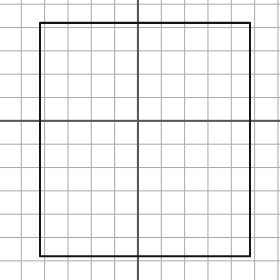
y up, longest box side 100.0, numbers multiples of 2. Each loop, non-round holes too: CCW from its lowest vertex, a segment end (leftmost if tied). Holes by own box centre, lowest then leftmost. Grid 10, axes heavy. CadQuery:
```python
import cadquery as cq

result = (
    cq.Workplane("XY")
    .moveTo(-42.0, -58.0)
    .lineTo(48.0, -58.0)
    .lineTo(48.0, 42.0)
    .lineTo(-42.0, 42.0)
    .close()
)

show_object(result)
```